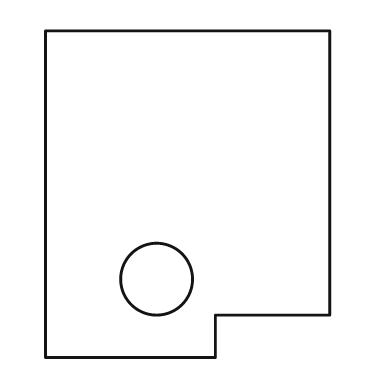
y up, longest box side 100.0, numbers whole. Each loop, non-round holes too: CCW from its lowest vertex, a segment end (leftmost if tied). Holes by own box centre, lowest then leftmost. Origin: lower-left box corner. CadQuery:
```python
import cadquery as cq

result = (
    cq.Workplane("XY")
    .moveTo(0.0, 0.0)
    .lineTo(52.0, 0.0)
    .lineTo(52.0, 13.0)
    .lineTo(87.0, 13.0)
    .lineTo(87.0, 100.0)
    .lineTo(0.0, 100.0)
    .close()
    .moveTo(34.0, 24.0)
    .circle(11.0)
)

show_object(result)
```